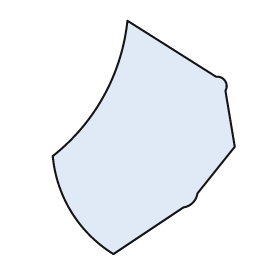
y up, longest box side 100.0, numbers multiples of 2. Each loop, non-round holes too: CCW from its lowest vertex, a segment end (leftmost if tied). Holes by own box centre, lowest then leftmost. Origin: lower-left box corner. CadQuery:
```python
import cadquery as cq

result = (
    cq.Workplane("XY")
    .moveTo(26.0, 0.0)
    .lineTo(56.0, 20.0)
    .threePointArc((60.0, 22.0), (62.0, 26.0))
    .lineTo(78.0, 46.0)
    .lineTo(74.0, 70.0)
    .threePointArc((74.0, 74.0), (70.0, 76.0))
    .lineTo(32.0, 100.0)
    .threePointArc((22.0, 68.0), (0.0, 42.0))
    .threePointArc((8.0, 18.0), (26.0, 0.0))
    .close()
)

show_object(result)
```